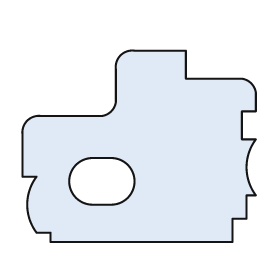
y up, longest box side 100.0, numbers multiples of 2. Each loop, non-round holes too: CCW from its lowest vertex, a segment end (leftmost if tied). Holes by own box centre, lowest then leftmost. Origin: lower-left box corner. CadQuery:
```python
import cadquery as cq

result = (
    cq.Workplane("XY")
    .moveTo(12.0, 0.0)
    .lineTo(90.0, 0.0)
    .lineTo(90.0, 10.0)
    .lineTo(96.0, 10.0)
    .lineTo(96.0, 20.0)
    .lineTo(100.0, 20.0)
    .threePointArc((96.0, 32.0), (100.0, 44.0))
    .lineTo(94.0, 44.0)
    .lineTo(94.0, 56.0)
    .lineTo(100.0, 56.0)
    .lineTo(100.0, 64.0)
    .threePointArc((98.0, 68.0), (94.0, 70.0))
    .lineTo(70.0, 70.0)
    .lineTo(70.0, 82.0)
    .lineTo(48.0, 82.0)
    .threePointArc((42.0, 80.0), (40.0, 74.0))
    .lineTo(40.0, 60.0)
    .threePointArc((38.0, 56.0), (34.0, 54.0))
    .lineTo(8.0, 54.0)
    .threePointArc((2.0, 52.0), (0.0, 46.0))
    .lineTo(0.0, 28.0)
    .lineTo(6.0, 28.0)
    .threePointArc((2.0, 16.0), (6.0, 4.0))
    .lineTo(12.0, 4.0)
    .close()
    .moveTo(30.0, 16.0)
    .lineTo(38.0, 16.0)
    .threePointArc((48.0, 26.0), (38.0, 36.0))
    .lineTo(30.0, 36.0)
    .threePointArc((20.0, 26.0), (30.0, 16.0))
    .close()
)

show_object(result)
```